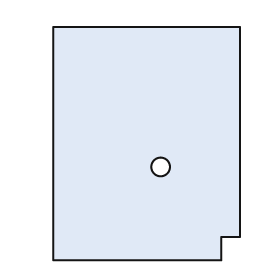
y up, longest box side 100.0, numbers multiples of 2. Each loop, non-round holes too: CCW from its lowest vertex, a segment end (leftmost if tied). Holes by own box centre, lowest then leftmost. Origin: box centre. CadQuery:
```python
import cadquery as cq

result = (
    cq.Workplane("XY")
    .moveTo(-40.0, -50.0)
    .lineTo(32.0, -50.0)
    .lineTo(32.0, -40.0)
    .lineTo(40.0, -40.0)
    .lineTo(40.0, 50.0)
    .lineTo(-40.0, 50.0)
    .close()
    .moveTo(6.0, -10.0)
    .circle(4.0)
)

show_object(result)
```